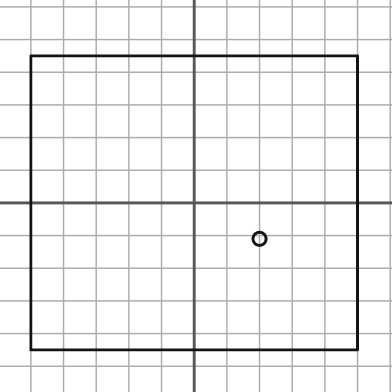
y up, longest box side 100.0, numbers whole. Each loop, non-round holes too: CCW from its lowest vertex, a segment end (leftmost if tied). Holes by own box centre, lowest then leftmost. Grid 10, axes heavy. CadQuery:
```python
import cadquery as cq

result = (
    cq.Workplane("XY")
    .moveTo(-50.0, -45.0)
    .lineTo(50.0, -45.0)
    .lineTo(50.0, 45.0)
    .lineTo(-50.0, 45.0)
    .close()
    .moveTo(20.0, -11.0)
    .circle(2.0)
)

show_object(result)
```